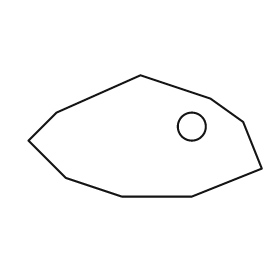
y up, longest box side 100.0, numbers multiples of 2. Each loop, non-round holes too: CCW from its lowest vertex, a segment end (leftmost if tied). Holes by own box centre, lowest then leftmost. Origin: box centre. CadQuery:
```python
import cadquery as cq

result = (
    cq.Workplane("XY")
    .moveTo(-10.0, -26.0)
    .lineTo(20.0, -26.0)
    .lineTo(50.0, -14.0)
    .lineTo(42.0, 6.0)
    .lineTo(28.0, 16.0)
    .lineTo(-2.0, 26.0)
    .lineTo(-38.0, 10.0)
    .lineTo(-50.0, -2.0)
    .lineTo(-34.0, -18.0)
    .close()
    .moveTo(20.0, 4.0)
    .circle(6.0)
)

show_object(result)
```